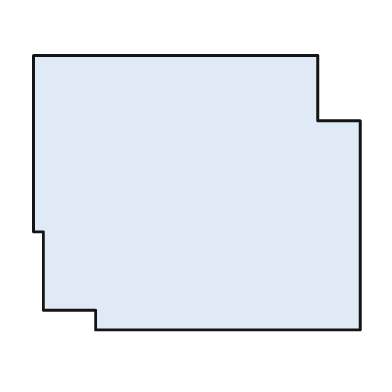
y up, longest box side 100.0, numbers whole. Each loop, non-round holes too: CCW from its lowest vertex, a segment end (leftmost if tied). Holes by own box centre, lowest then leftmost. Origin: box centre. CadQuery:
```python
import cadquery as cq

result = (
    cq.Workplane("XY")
    .moveTo(-31.0, -42.0)
    .lineTo(50.0, -42.0)
    .lineTo(50.0, 22.0)
    .lineTo(37.0, 22.0)
    .lineTo(37.0, 42.0)
    .lineTo(-50.0, 42.0)
    .lineTo(-50.0, -12.0)
    .lineTo(-47.0, -12.0)
    .lineTo(-47.0, -36.0)
    .lineTo(-31.0, -36.0)
    .close()
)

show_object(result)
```